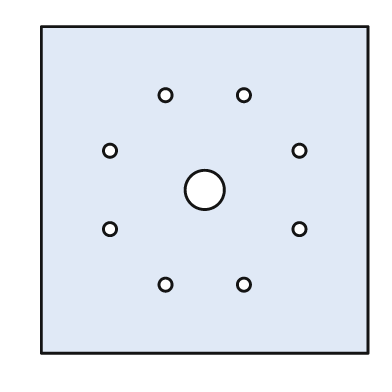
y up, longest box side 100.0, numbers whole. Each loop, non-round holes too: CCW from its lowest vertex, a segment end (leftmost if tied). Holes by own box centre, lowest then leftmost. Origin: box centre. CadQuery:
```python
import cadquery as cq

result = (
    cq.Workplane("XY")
    .moveTo(-50.0, -50.0)
    .lineTo(50.0, -50.0)
    .lineTo(50.0, 50.0)
    .lineTo(-50.0, 50.0)
    .close()
    .moveTo(-12.0, -29.0)
    .circle(2.0)
    .moveTo(12.0, -29.0)
    .circle(2.0)
    .moveTo(-29.0, -12.0)
    .circle(2.0)
    .moveTo(29.0, -12.0)
    .circle(2.0)
    .moveTo(0.0, 0.0)
    .circle(6.0)
    .moveTo(-29.0, 12.0)
    .circle(2.0)
    .moveTo(29.0, 12.0)
    .circle(2.0)
    .moveTo(-12.0, 29.0)
    .circle(2.0)
    .moveTo(12.0, 29.0)
    .circle(2.0)
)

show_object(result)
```